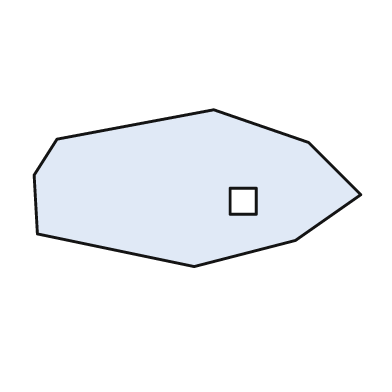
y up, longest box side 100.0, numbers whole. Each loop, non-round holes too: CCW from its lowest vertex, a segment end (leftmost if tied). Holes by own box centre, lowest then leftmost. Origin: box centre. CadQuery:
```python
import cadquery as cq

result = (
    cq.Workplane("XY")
    .moveTo(-1.0, -24.0)
    .lineTo(30.0, -16.0)
    .lineTo(50.0, -2.0)
    .lineTo(34.0, 14.0)
    .lineTo(5.0, 24.0)
    .lineTo(-43.0, 15.0)
    .lineTo(-50.0, 4.0)
    .lineTo(-49.0, -14.0)
    .close()
    .moveTo(10.0, -8.0)
    .lineTo(18.0, -8.0)
    .lineTo(18.0, 0.0)
    .lineTo(10.0, 0.0)
    .close()
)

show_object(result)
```